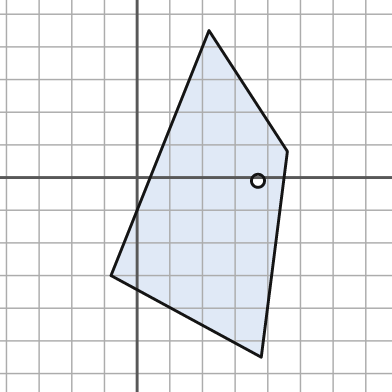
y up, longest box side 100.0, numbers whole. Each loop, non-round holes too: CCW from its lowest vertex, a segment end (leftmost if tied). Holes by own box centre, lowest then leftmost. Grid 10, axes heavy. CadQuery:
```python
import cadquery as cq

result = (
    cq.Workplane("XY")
    .moveTo(38.0, -55.0)
    .lineTo(46.0, 8.0)
    .lineTo(22.0, 45.0)
    .lineTo(-8.0, -30.0)
    .close()
    .moveTo(37.0, -1.0)
    .circle(2.0)
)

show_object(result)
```